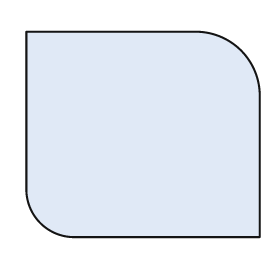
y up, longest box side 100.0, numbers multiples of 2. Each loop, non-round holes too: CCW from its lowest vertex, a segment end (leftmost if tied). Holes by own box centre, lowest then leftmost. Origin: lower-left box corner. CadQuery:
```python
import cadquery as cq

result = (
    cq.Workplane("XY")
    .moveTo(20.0, 0.0)
    .lineTo(100.0, 0.0)
    .lineTo(100.0, 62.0)
    .threePointArc((92.0, 80.0), (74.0, 88.0))
    .lineTo(0.0, 88.0)
    .lineTo(0.0, 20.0)
    .threePointArc((6.0, 6.0), (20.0, 0.0))
    .close()
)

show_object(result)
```